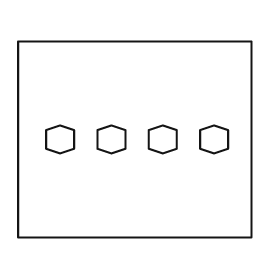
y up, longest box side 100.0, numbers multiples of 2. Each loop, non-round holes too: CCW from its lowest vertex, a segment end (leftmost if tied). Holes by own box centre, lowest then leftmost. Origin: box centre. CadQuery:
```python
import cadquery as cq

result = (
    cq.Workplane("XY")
    .moveTo(-50.0, -42.0)
    .lineTo(50.0, -42.0)
    .lineTo(50.0, 42.0)
    .lineTo(-50.0, 42.0)
    .close()
    .moveTo(-32.0, -6.0)
    .lineTo(-26.0, -4.0)
    .lineTo(-26.0, 4.0)
    .lineTo(-32.0, 6.0)
    .lineTo(-38.0, 4.0)
    .lineTo(-38.0, -4.0)
    .close()
    .moveTo(-10.0, -6.0)
    .lineTo(-4.0, -4.0)
    .lineTo(-4.0, 4.0)
    .lineTo(-10.0, 6.0)
    .lineTo(-16.0, 4.0)
    .lineTo(-16.0, -4.0)
    .close()
    .moveTo(12.0, -6.0)
    .lineTo(18.0, -4.0)
    .lineTo(18.0, 4.0)
    .lineTo(12.0, 6.0)
    .lineTo(6.0, 4.0)
    .lineTo(6.0, -4.0)
    .close()
    .moveTo(34.0, -6.0)
    .lineTo(40.0, -4.0)
    .lineTo(40.0, 4.0)
    .lineTo(34.0, 6.0)
    .lineTo(28.0, 4.0)
    .lineTo(28.0, -4.0)
    .close()
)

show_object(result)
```